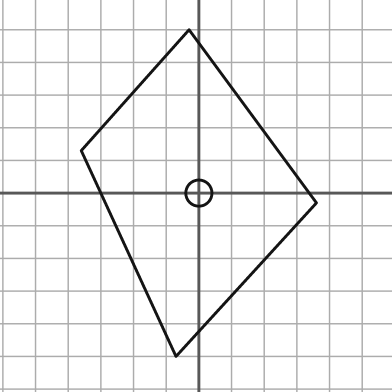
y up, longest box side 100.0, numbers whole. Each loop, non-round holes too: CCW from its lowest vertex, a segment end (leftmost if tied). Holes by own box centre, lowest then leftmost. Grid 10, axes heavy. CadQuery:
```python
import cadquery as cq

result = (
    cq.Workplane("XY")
    .moveTo(-7.0, -50.0)
    .lineTo(36.0, -3.0)
    .lineTo(-3.0, 50.0)
    .lineTo(-36.0, 13.0)
    .close()
    .moveTo(0.0, 0.0)
    .circle(4.0)
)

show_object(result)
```